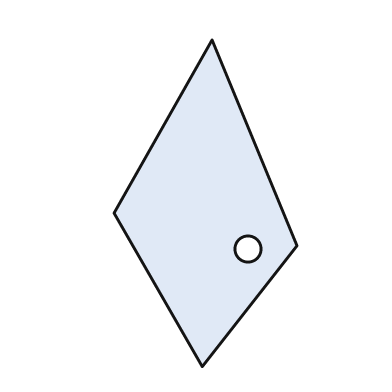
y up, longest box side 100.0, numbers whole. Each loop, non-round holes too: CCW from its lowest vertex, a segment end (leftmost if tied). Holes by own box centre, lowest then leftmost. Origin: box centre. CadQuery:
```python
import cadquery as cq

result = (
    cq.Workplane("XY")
    .moveTo(-1.0, -50.0)
    .lineTo(28.0, -13.0)
    .lineTo(2.0, 50.0)
    .lineTo(-28.0, -3.0)
    .close()
    .moveTo(13.0, -14.0)
    .circle(4.0)
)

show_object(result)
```